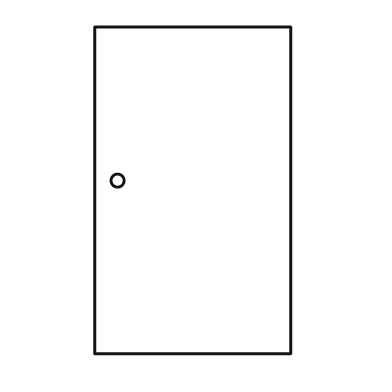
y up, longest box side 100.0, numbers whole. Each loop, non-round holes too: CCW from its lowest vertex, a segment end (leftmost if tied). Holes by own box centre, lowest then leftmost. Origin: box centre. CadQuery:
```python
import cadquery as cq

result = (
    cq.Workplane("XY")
    .moveTo(-30.0, -50.0)
    .lineTo(30.0, -50.0)
    .lineTo(30.0, 50.0)
    .lineTo(-30.0, 50.0)
    .close()
    .moveTo(-23.0, 3.0)
    .circle(2.0)
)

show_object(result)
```